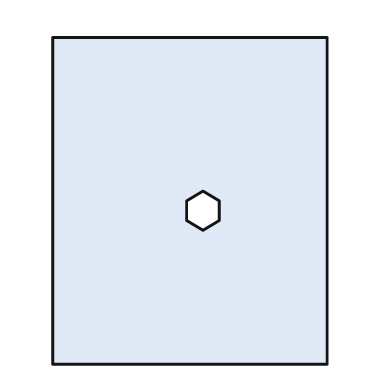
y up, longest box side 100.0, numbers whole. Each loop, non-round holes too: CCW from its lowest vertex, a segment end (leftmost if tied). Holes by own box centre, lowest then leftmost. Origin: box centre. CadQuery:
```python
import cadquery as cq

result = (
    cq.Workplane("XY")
    .moveTo(-42.0, -50.0)
    .lineTo(42.0, -50.0)
    .lineTo(42.0, 50.0)
    .lineTo(-42.0, 50.0)
    .close()
    .moveTo(4.0, -9.0)
    .lineTo(9.0, -6.0)
    .lineTo(9.0, 0.0)
    .lineTo(4.0, 3.0)
    .lineTo(-1.0, 0.0)
    .lineTo(-1.0, -6.0)
    .close()
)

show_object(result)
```